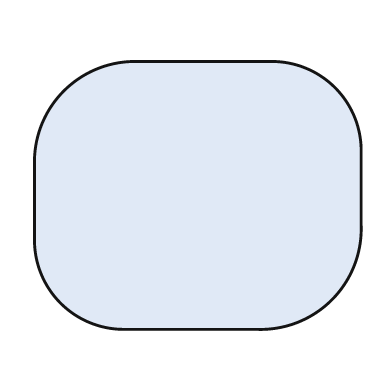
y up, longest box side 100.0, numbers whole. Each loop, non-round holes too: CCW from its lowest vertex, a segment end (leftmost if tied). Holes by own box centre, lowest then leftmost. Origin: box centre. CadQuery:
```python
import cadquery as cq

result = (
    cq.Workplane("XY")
    .moveTo(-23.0, -41.0)
    .lineTo(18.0, -41.0)
    .threePointArc((41.0, -32.0), (50.0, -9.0))
    .lineTo(50.0, 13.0)
    .threePointArc((42.0, 33.0), (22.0, 41.0))
    .lineTo(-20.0, 41.0)
    .threePointArc((-41.0, 32.0), (-50.0, 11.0))
    .lineTo(-50.0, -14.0)
    .threePointArc((-42.0, -33.0), (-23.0, -41.0))
    .close()
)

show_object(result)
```